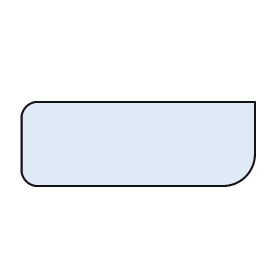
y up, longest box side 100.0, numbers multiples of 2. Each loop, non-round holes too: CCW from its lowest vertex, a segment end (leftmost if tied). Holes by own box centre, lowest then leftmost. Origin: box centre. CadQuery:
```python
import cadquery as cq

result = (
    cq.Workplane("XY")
    .moveTo(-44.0, -18.0)
    .lineTo(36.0, -18.0)
    .threePointArc((46.0, -14.0), (50.0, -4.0))
    .lineTo(50.0, 18.0)
    .lineTo(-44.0, 18.0)
    .threePointArc((-48.0, 16.0), (-50.0, 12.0))
    .lineTo(-50.0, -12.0)
    .threePointArc((-48.0, -16.0), (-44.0, -18.0))
    .close()
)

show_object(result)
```